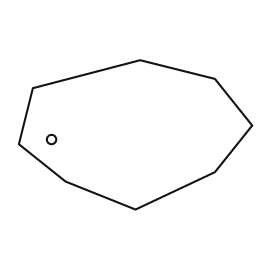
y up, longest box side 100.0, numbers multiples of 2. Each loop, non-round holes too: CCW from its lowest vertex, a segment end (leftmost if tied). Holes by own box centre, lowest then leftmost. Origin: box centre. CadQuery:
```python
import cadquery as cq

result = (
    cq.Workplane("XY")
    .moveTo(0.0, -32.0)
    .lineTo(34.0, -16.0)
    .lineTo(50.0, 4.0)
    .lineTo(34.0, 24.0)
    .lineTo(2.0, 32.0)
    .lineTo(-44.0, 20.0)
    .lineTo(-50.0, -4.0)
    .lineTo(-30.0, -20.0)
    .close()
    .moveTo(-36.0, -2.0)
    .circle(2.0)
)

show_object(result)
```